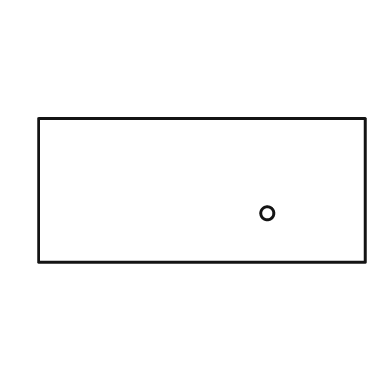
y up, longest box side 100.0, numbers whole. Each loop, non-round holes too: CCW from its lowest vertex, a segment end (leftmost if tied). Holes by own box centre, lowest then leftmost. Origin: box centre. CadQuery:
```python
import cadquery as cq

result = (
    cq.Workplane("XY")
    .moveTo(-50.0, -22.0)
    .lineTo(50.0, -22.0)
    .lineTo(50.0, 22.0)
    .lineTo(-50.0, 22.0)
    .close()
    .moveTo(20.0, -7.0)
    .circle(2.0)
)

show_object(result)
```